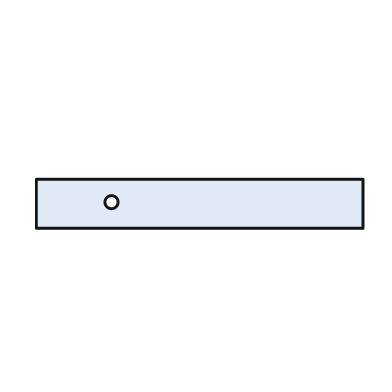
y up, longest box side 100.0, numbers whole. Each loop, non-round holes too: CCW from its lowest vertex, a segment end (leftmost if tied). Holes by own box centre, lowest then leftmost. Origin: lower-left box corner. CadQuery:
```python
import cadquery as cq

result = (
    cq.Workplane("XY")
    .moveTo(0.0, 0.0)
    .lineTo(100.0, 0.0)
    .lineTo(100.0, 15.0)
    .lineTo(0.0, 15.0)
    .close()
    .moveTo(23.0, 8.0)
    .circle(2.0)
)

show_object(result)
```